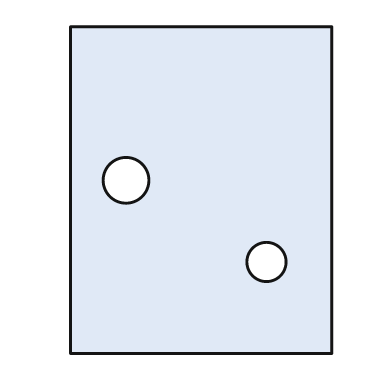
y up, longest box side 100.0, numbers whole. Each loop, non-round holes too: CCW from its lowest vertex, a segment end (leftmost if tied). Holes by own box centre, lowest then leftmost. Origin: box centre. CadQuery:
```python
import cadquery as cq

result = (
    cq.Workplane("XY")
    .moveTo(-40.0, -50.0)
    .lineTo(40.0, -50.0)
    .lineTo(40.0, 50.0)
    .lineTo(-40.0, 50.0)
    .close()
    .moveTo(20.0, -22.0)
    .circle(6.0)
    .moveTo(-23.0, 3.0)
    .circle(7.0)
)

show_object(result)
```